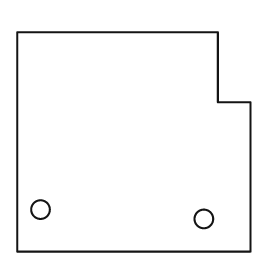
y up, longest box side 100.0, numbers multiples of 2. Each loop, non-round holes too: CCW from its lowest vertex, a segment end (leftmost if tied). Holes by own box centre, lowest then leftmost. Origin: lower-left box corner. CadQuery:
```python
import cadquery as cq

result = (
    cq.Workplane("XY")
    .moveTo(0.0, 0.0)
    .lineTo(100.0, 0.0)
    .lineTo(100.0, 64.0)
    .lineTo(86.0, 64.0)
    .lineTo(86.0, 94.0)
    .lineTo(0.0, 94.0)
    .close()
    .moveTo(80.0, 14.0)
    .circle(4.0)
    .moveTo(10.0, 18.0)
    .circle(4.0)
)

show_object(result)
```